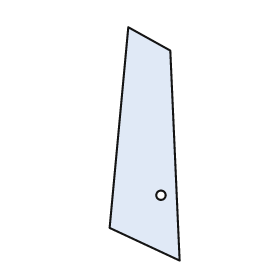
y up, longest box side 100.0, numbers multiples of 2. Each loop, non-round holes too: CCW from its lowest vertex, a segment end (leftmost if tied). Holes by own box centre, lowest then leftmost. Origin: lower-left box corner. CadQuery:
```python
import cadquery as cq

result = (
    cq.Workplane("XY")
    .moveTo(30.0, 0.0)
    .lineTo(26.0, 90.0)
    .lineTo(8.0, 100.0)
    .lineTo(0.0, 14.0)
    .close()
    .moveTo(22.0, 28.0)
    .circle(2.0)
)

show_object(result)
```